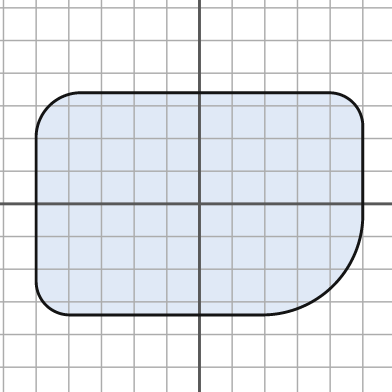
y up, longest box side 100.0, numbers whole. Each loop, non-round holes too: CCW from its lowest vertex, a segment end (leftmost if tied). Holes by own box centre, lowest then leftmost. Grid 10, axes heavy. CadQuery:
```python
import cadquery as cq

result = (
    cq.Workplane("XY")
    .moveTo(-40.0, -34.0)
    .lineTo(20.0, -34.0)
    .threePointArc((41.0, -25.0), (50.0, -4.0))
    .lineTo(50.0, 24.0)
    .threePointArc((47.0, 31.0), (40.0, 34.0))
    .lineTo(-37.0, 34.0)
    .threePointArc((-46.0, 30.0), (-50.0, 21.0))
    .lineTo(-50.0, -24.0)
    .threePointArc((-47.0, -31.0), (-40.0, -34.0))
    .close()
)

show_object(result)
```